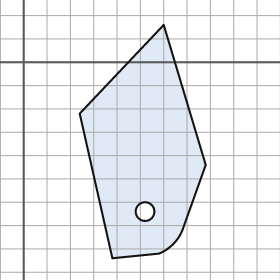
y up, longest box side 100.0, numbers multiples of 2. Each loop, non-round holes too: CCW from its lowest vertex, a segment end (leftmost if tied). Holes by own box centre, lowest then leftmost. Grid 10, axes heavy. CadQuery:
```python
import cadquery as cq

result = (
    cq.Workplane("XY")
    .moveTo(38.0, -84.0)
    .lineTo(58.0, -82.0)
    .threePointArc((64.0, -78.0), (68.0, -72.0))
    .lineTo(78.0, -44.0)
    .lineTo(60.0, 16.0)
    .lineTo(24.0, -22.0)
    .close()
    .moveTo(52.0, -64.0)
    .circle(4.0)
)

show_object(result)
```